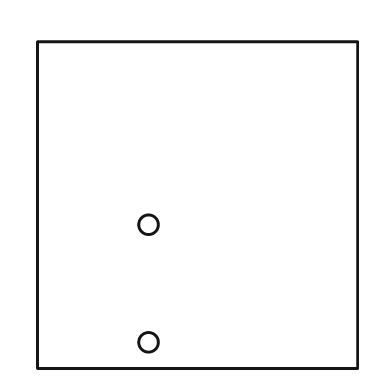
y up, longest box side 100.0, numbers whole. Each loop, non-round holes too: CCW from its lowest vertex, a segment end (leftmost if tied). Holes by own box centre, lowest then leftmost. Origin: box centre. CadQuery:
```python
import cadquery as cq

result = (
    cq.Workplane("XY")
    .moveTo(-49.0, -50.0)
    .lineTo(49.0, -50.0)
    .lineTo(49.0, 50.0)
    .lineTo(-49.0, 50.0)
    .close()
    .moveTo(-15.0, -42.0)
    .circle(3.0)
    .moveTo(-15.0, -6.0)
    .circle(3.0)
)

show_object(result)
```